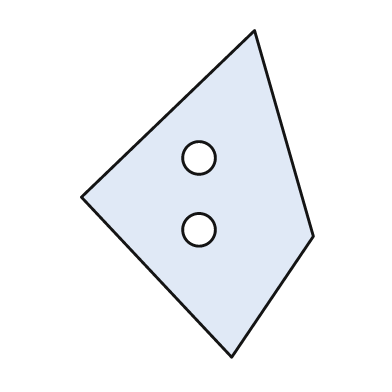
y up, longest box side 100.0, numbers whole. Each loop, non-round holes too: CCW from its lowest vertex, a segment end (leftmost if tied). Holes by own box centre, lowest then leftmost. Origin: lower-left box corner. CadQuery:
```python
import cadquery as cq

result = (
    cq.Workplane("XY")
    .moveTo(46.0, 0.0)
    .lineTo(71.0, 37.0)
    .lineTo(53.0, 100.0)
    .lineTo(0.0, 49.0)
    .close()
    .moveTo(36.0, 39.0)
    .circle(5.0)
    .moveTo(36.0, 61.0)
    .circle(5.0)
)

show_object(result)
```